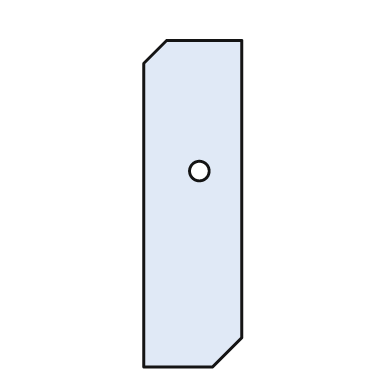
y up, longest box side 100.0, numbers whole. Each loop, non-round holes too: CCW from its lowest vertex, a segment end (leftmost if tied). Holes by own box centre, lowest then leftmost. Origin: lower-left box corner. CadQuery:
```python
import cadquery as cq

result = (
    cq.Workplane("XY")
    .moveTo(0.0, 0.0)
    .lineTo(21.0, 0.0)
    .lineTo(30.0, 9.0)
    .lineTo(30.0, 100.0)
    .lineTo(7.0, 100.0)
    .lineTo(0.0, 93.0)
    .close()
    .moveTo(17.0, 60.0)
    .circle(3.0)
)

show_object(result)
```